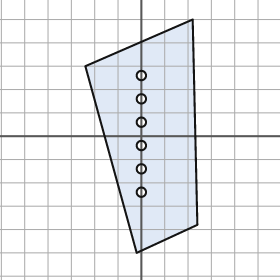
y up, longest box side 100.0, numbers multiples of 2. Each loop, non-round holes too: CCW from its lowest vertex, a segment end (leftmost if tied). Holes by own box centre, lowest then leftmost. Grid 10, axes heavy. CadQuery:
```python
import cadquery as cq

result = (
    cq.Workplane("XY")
    .moveTo(-2.0, -50.0)
    .lineTo(24.0, -38.0)
    .lineTo(22.0, 50.0)
    .lineTo(-24.0, 30.0)
    .close()
    .moveTo(0.0, -24.0)
    .circle(2.0)
    .moveTo(0.0, -14.0)
    .circle(2.0)
    .moveTo(0.0, -4.0)
    .circle(2.0)
    .moveTo(0.0, 6.0)
    .circle(2.0)
    .moveTo(0.0, 16.0)
    .circle(2.0)
    .moveTo(0.0, 26.0)
    .circle(2.0)
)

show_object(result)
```